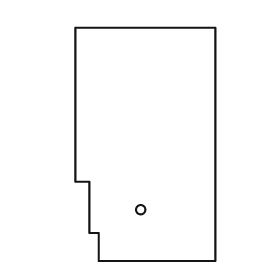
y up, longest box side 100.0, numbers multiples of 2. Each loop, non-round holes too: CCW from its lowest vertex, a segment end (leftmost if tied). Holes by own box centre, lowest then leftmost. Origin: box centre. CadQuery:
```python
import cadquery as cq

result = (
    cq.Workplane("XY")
    .moveTo(-20.0, -50.0)
    .lineTo(30.0, -50.0)
    .lineTo(30.0, 50.0)
    .lineTo(-30.0, 50.0)
    .lineTo(-30.0, -16.0)
    .lineTo(-24.0, -16.0)
    .lineTo(-24.0, -38.0)
    .lineTo(-20.0, -38.0)
    .close()
    .moveTo(-2.0, -28.0)
    .circle(2.0)
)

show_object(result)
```